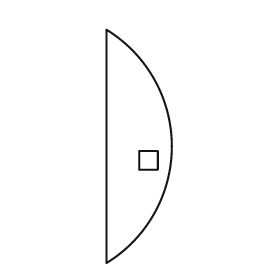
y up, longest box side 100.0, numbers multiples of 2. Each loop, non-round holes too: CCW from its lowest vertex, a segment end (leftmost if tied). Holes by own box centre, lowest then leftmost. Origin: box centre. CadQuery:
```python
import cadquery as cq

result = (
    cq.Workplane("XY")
    .moveTo(-14.0, -50.0)
    .threePointArc((14.0, 0.0), (-14.0, 50.0))
    .close()
    .moveTo(0.0, -10.0)
    .lineTo(8.0, -10.0)
    .lineTo(8.0, -2.0)
    .lineTo(0.0, -2.0)
    .close()
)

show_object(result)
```